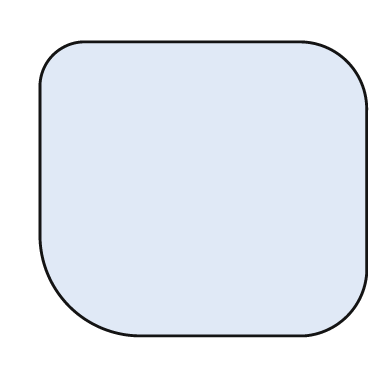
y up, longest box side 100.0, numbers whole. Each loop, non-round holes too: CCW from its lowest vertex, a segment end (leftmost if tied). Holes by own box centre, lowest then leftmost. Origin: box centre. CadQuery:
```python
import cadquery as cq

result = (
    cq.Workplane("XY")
    .moveTo(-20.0, -45.0)
    .lineTo(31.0, -45.0)
    .threePointArc((44.0, -39.0), (50.0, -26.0))
    .lineTo(50.0, 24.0)
    .threePointArc((44.0, 39.0), (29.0, 45.0))
    .lineTo(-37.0, 45.0)
    .threePointArc((-46.0, 41.0), (-50.0, 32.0))
    .lineTo(-50.0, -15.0)
    .threePointArc((-41.0, -36.0), (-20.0, -45.0))
    .close()
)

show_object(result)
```